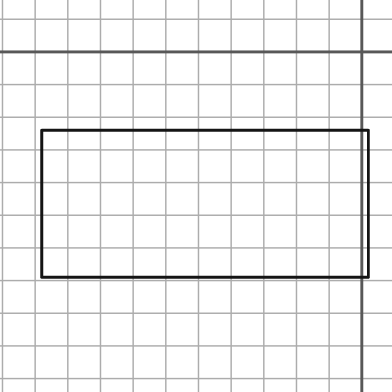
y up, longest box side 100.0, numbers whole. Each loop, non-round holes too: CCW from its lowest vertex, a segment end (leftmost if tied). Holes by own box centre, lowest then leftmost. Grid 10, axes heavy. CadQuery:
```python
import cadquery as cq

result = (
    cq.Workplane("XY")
    .moveTo(-98.0, -69.0)
    .lineTo(2.0, -69.0)
    .lineTo(2.0, -24.0)
    .lineTo(-98.0, -24.0)
    .close()
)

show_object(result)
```